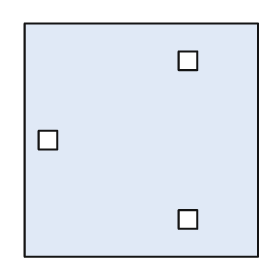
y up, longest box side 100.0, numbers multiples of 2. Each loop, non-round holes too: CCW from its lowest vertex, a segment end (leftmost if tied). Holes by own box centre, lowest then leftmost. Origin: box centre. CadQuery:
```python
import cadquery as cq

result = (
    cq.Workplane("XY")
    .moveTo(-50.0, -50.0)
    .lineTo(50.0, -50.0)
    .lineTo(50.0, 50.0)
    .lineTo(-50.0, 50.0)
    .close()
    .moveTo(16.0, -38.0)
    .lineTo(24.0, -38.0)
    .lineTo(24.0, -30.0)
    .lineTo(16.0, -30.0)
    .close()
    .moveTo(-44.0, -4.0)
    .lineTo(-36.0, -4.0)
    .lineTo(-36.0, 4.0)
    .lineTo(-44.0, 4.0)
    .close()
    .moveTo(16.0, 30.0)
    .lineTo(24.0, 30.0)
    .lineTo(24.0, 38.0)
    .lineTo(16.0, 38.0)
    .close()
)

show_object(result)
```